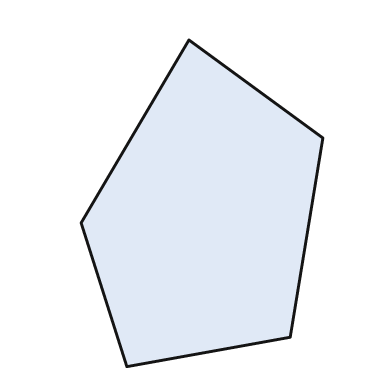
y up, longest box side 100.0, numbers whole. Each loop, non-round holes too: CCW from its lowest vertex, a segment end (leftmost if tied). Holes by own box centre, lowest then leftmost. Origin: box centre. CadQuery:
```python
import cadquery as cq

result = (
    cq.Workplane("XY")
    .moveTo(-23.0, -50.0)
    .lineTo(27.0, -41.0)
    .lineTo(37.0, 20.0)
    .lineTo(-4.0, 50.0)
    .lineTo(-37.0, -6.0)
    .close()
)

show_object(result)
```